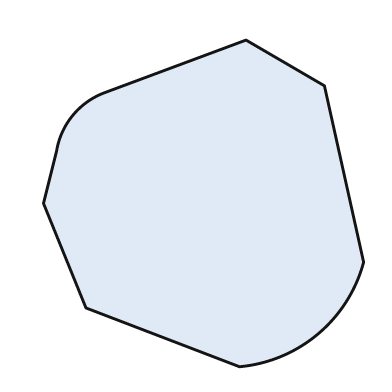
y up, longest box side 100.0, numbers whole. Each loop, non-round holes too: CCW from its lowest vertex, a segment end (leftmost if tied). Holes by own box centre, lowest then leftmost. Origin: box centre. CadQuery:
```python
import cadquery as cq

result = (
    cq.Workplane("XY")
    .moveTo(11.0, -50.0)
    .threePointArc((35.0, -40.0), (49.0, -18.0))
    .lineTo(37.0, 36.0)
    .lineTo(13.0, 50.0)
    .lineTo(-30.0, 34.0)
    .threePointArc((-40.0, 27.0), (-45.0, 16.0))
    .lineTo(-49.0, 0.0)
    .lineTo(-36.0, -32.0)
    .close()
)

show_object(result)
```